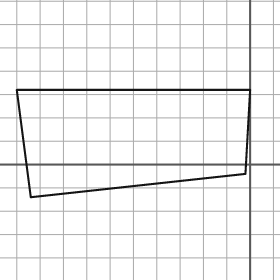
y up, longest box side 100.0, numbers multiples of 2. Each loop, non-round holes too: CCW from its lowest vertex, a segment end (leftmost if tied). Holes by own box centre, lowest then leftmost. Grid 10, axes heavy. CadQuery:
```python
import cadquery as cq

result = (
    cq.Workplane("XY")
    .moveTo(-94.0, -14.0)
    .lineTo(-2.0, -4.0)
    .lineTo(0.0, 32.0)
    .lineTo(-100.0, 32.0)
    .close()
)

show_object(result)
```